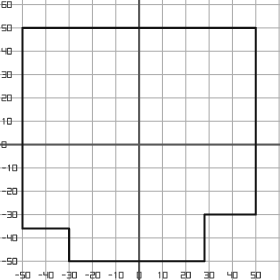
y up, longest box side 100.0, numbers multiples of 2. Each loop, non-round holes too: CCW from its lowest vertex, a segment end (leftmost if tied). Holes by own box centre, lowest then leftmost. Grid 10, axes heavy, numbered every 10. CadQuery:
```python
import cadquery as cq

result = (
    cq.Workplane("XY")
    .moveTo(-30.0, -50.0)
    .lineTo(28.0, -50.0)
    .lineTo(28.0, -30.0)
    .lineTo(50.0, -30.0)
    .lineTo(50.0, 50.0)
    .lineTo(-50.0, 50.0)
    .lineTo(-50.0, -36.0)
    .lineTo(-30.0, -36.0)
    .close()
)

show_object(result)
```